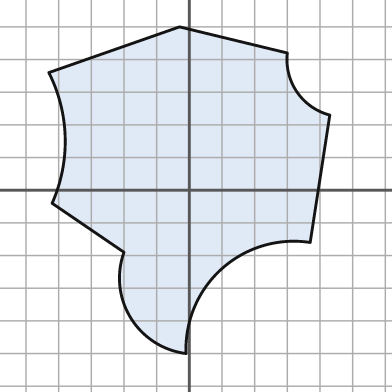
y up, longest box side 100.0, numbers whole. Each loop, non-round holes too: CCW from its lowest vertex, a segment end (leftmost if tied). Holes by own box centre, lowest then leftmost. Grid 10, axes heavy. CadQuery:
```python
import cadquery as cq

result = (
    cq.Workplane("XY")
    .moveTo(-1.0, -50.0)
    .threePointArc((10.0, -24.0), (37.0, -16.0))
    .lineTo(43.0, 23.0)
    .threePointArc((33.0, 30.0), (30.0, 42.0))
    .lineTo(-3.0, 50.0)
    .lineTo(-43.0, 36.0)
    .threePointArc((-38.0, 16.0), (-42.0, -4.0))
    .lineTo(-20.0, -19.0)
    .threePointArc((-18.0, -39.0), (-1.0, -50.0))
    .close()
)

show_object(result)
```